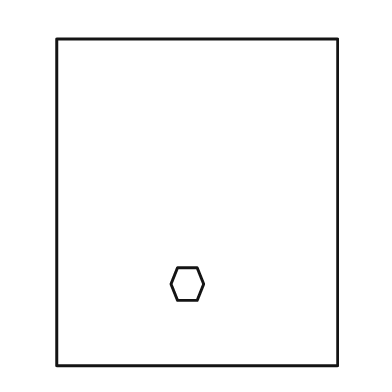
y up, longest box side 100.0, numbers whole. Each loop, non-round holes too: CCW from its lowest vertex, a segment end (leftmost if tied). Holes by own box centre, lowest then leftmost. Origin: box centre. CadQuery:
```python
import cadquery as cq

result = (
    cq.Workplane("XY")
    .moveTo(-43.0, -50.0)
    .lineTo(43.0, -50.0)
    .lineTo(43.0, 50.0)
    .lineTo(-43.0, 50.0)
    .close()
    .moveTo(-6.0, -30.0)
    .lineTo(0.0, -30.0)
    .lineTo(2.0, -25.0)
    .lineTo(0.0, -20.0)
    .lineTo(-6.0, -20.0)
    .lineTo(-8.0, -25.0)
    .close()
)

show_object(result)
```